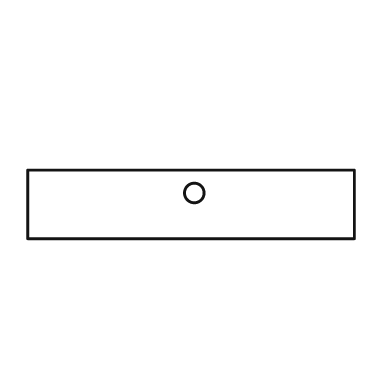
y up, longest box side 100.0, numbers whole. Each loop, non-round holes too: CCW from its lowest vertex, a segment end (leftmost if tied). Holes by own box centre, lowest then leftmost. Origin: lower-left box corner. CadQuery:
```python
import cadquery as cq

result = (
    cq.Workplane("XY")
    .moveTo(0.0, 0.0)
    .lineTo(100.0, 0.0)
    .lineTo(100.0, 21.0)
    .lineTo(0.0, 21.0)
    .close()
    .moveTo(51.0, 14.0)
    .circle(3.0)
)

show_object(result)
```